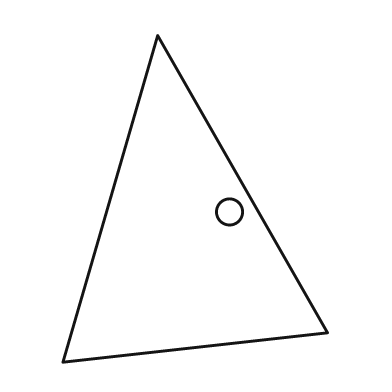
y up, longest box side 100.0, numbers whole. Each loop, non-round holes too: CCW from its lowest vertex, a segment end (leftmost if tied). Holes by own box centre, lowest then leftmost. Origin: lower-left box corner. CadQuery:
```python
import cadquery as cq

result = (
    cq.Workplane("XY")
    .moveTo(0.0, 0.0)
    .lineTo(81.0, 9.0)
    .lineTo(29.0, 100.0)
    .close()
    .moveTo(51.0, 46.0)
    .circle(4.0)
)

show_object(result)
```